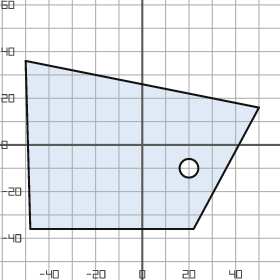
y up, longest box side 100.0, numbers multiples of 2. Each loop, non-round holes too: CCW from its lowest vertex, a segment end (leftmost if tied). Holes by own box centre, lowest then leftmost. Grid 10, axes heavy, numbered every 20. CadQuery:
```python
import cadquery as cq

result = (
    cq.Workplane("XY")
    .moveTo(-48.0, -36.0)
    .lineTo(22.0, -36.0)
    .lineTo(50.0, 16.0)
    .lineTo(-50.0, 36.0)
    .close()
    .moveTo(20.0, -10.0)
    .circle(4.0)
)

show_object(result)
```